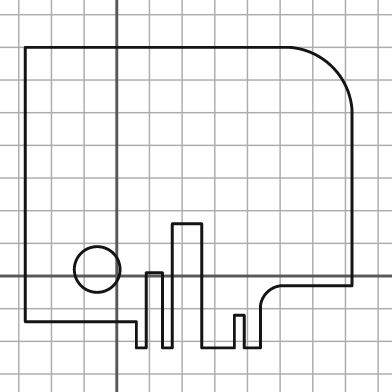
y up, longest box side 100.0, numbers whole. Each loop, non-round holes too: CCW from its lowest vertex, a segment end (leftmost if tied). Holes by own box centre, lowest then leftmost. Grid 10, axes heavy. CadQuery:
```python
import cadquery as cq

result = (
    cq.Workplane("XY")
    .moveTo(6.0, -22.0)
    .lineTo(9.0, -22.0)
    .lineTo(9.0, 1.0)
    .lineTo(14.0, 1.0)
    .lineTo(14.0, -22.0)
    .lineTo(17.0, -22.0)
    .lineTo(17.0, 16.0)
    .lineTo(26.0, 16.0)
    .lineTo(26.0, -22.0)
    .lineTo(36.0, -22.0)
    .lineTo(36.0, -12.0)
    .lineTo(39.0, -12.0)
    .lineTo(39.0, -22.0)
    .lineTo(44.0, -22.0)
    .lineTo(44.0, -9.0)
    .threePointArc((46.0, -5.0), (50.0, -3.0))
    .lineTo(72.0, -3.0)
    .lineTo(72.0, 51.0)
    .threePointArc((66.0, 64.0), (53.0, 70.0))
    .lineTo(-28.0, 70.0)
    .lineTo(-28.0, -14.0)
    .lineTo(6.0, -14.0)
    .close()
    .moveTo(-6.0, 2.0)
    .circle(7.0)
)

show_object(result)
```